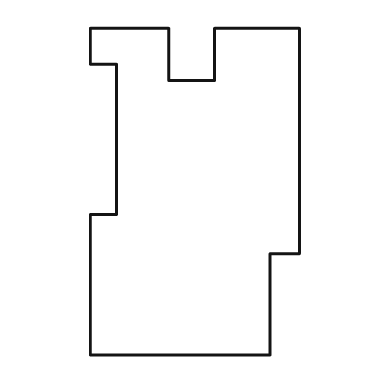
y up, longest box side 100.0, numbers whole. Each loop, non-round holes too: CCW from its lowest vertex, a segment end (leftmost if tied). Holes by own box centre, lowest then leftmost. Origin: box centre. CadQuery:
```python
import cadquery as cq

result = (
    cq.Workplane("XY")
    .moveTo(-32.0, -50.0)
    .lineTo(23.0, -50.0)
    .lineTo(23.0, -19.0)
    .lineTo(32.0, -19.0)
    .lineTo(32.0, 50.0)
    .lineTo(6.0, 50.0)
    .lineTo(6.0, 34.0)
    .lineTo(-8.0, 34.0)
    .lineTo(-8.0, 50.0)
    .lineTo(-32.0, 50.0)
    .lineTo(-32.0, 39.0)
    .lineTo(-24.0, 39.0)
    .lineTo(-24.0, -7.0)
    .lineTo(-32.0, -7.0)
    .close()
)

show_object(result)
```